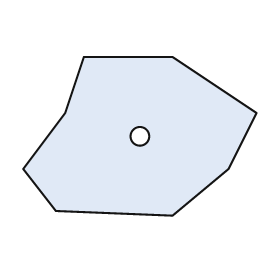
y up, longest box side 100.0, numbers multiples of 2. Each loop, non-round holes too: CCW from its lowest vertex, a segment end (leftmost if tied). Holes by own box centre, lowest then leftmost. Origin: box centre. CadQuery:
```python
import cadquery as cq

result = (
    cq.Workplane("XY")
    .moveTo(14.0, -34.0)
    .lineTo(38.0, -14.0)
    .lineTo(50.0, 10.0)
    .lineTo(14.0, 34.0)
    .lineTo(-24.0, 34.0)
    .lineTo(-32.0, 10.0)
    .lineTo(-50.0, -14.0)
    .lineTo(-36.0, -32.0)
    .close()
    .moveTo(0.0, 0.0)
    .circle(4.0)
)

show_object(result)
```